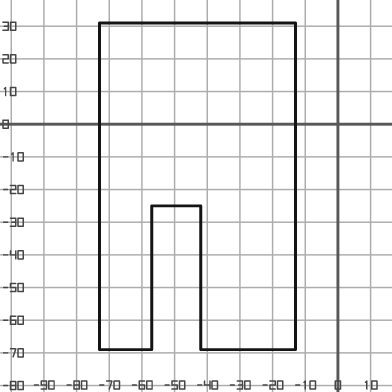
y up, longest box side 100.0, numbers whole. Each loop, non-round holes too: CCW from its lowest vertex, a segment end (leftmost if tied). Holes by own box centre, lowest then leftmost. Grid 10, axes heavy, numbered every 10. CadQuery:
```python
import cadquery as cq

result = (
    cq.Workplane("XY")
    .moveTo(-73.0, -69.0)
    .lineTo(-57.0, -69.0)
    .lineTo(-57.0, -25.0)
    .lineTo(-42.0, -25.0)
    .lineTo(-42.0, -69.0)
    .lineTo(-13.0, -69.0)
    .lineTo(-13.0, 31.0)
    .lineTo(-73.0, 31.0)
    .close()
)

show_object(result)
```